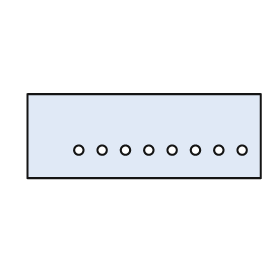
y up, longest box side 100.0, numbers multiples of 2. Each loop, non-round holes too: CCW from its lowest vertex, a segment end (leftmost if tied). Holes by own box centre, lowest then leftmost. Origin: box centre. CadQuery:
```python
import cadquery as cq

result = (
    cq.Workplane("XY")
    .moveTo(-50.0, -18.0)
    .lineTo(50.0, -18.0)
    .lineTo(50.0, 18.0)
    .lineTo(-50.0, 18.0)
    .close()
    .moveTo(-28.0, -6.0)
    .circle(2.0)
    .moveTo(-18.0, -6.0)
    .circle(2.0)
    .moveTo(-8.0, -6.0)
    .circle(2.0)
    .moveTo(2.0, -6.0)
    .circle(2.0)
    .moveTo(12.0, -6.0)
    .circle(2.0)
    .moveTo(22.0, -6.0)
    .circle(2.0)
    .moveTo(32.0, -6.0)
    .circle(2.0)
    .moveTo(42.0, -6.0)
    .circle(2.0)
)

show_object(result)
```